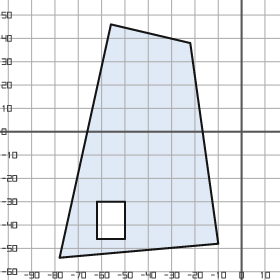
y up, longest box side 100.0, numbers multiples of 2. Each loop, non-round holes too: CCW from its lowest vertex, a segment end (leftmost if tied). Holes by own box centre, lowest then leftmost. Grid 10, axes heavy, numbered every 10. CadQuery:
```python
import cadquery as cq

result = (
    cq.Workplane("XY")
    .moveTo(-78.0, -54.0)
    .lineTo(-10.0, -48.0)
    .lineTo(-22.0, 38.0)
    .lineTo(-56.0, 46.0)
    .close()
    .moveTo(-62.0, -46.0)
    .lineTo(-50.0, -46.0)
    .lineTo(-50.0, -30.0)
    .lineTo(-62.0, -30.0)
    .close()
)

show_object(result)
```